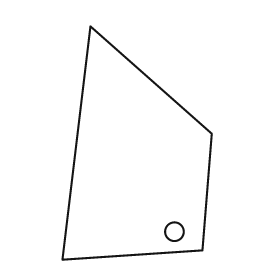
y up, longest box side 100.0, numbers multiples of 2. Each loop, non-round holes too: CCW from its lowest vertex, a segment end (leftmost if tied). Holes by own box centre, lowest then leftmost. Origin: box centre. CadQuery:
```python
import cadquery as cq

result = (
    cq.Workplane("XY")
    .moveTo(-32.0, -50.0)
    .lineTo(28.0, -46.0)
    .lineTo(32.0, 4.0)
    .lineTo(-20.0, 50.0)
    .close()
    .moveTo(16.0, -38.0)
    .circle(4.0)
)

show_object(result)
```